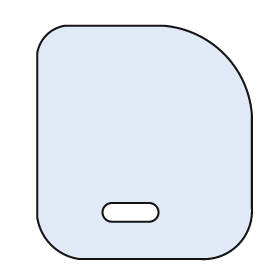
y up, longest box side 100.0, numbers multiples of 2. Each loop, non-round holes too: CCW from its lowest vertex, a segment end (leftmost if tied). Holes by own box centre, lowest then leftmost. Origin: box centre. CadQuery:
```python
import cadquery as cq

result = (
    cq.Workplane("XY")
    .moveTo(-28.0, -50.0)
    .lineTo(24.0, -50.0)
    .threePointArc((40.0, -44.0), (46.0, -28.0))
    .lineTo(46.0, 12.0)
    .threePointArc((34.0, 38.0), (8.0, 50.0))
    .lineTo(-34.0, 50.0)
    .threePointArc((-42.0, 46.0), (-46.0, 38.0))
    .lineTo(-46.0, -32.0)
    .threePointArc((-40.0, -44.0), (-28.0, -50.0))
    .close()
    .moveTo(-14.0, -34.0)
    .lineTo(2.0, -34.0)
    .threePointArc((6.0, -30.0), (2.0, -26.0))
    .lineTo(-14.0, -26.0)
    .threePointArc((-18.0, -30.0), (-14.0, -34.0))
    .close()
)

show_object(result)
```